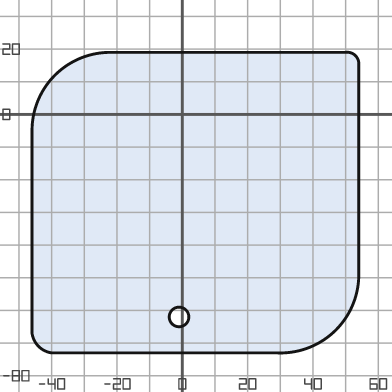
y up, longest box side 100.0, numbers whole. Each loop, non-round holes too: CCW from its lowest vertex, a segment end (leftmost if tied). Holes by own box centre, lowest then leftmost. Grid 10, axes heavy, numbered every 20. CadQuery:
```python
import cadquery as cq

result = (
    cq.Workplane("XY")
    .moveTo(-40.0, -73.0)
    .lineTo(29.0, -73.0)
    .threePointArc((47.0, -66.0), (54.0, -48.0))
    .lineTo(54.0, 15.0)
    .threePointArc((53.0, 18.0), (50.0, 19.0))
    .lineTo(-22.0, 19.0)
    .threePointArc((-39.0, 12.0), (-46.0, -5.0))
    .lineTo(-46.0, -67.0)
    .threePointArc((-44.0, -71.0), (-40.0, -73.0))
    .close()
    .moveTo(-1.0, -62.0)
    .circle(3.0)
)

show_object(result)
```